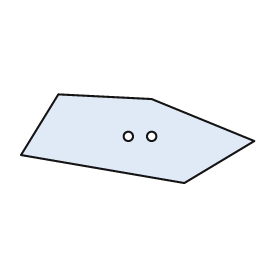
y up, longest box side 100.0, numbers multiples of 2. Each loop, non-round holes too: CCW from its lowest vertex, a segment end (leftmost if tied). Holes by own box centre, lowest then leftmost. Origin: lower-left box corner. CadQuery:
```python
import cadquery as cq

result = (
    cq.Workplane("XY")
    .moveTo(70.0, 0.0)
    .lineTo(100.0, 18.0)
    .lineTo(56.0, 36.0)
    .lineTo(16.0, 38.0)
    .lineTo(0.0, 12.0)
    .close()
    .moveTo(46.0, 20.0)
    .circle(2.0)
    .moveTo(56.0, 20.0)
    .circle(2.0)
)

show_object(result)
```